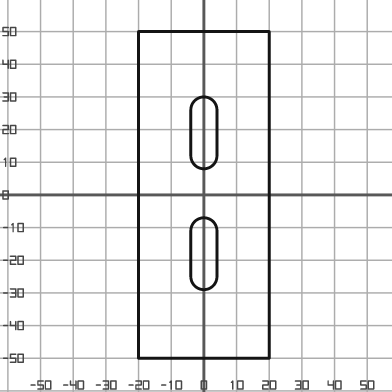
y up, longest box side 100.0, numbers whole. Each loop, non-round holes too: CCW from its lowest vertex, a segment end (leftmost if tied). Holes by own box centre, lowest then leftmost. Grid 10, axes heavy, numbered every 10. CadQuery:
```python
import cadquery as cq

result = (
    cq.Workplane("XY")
    .moveTo(-20.0, -50.0)
    .lineTo(20.0, -50.0)
    .lineTo(20.0, 50.0)
    .lineTo(-20.0, 50.0)
    .close()
    .moveTo(-4.0, -25.0)
    .threePointArc((0.0, -29.0), (4.0, -25.0))
    .lineTo(4.0, -11.0)
    .threePointArc((0.0, -7.0), (-4.0, -11.0))
    .close()
    .moveTo(-4.0, 12.0)
    .threePointArc((0.0, 8.0), (4.0, 12.0))
    .lineTo(4.0, 26.0)
    .threePointArc((0.0, 30.0), (-4.0, 26.0))
    .close()
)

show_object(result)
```